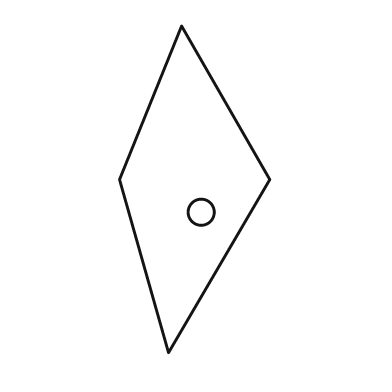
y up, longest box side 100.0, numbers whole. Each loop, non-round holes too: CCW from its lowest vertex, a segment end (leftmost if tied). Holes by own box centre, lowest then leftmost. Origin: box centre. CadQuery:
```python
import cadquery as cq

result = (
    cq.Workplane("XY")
    .moveTo(-8.0, -50.0)
    .lineTo(23.0, 3.0)
    .lineTo(-4.0, 50.0)
    .lineTo(-23.0, 3.0)
    .close()
    .moveTo(2.0, -7.0)
    .circle(4.0)
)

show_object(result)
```